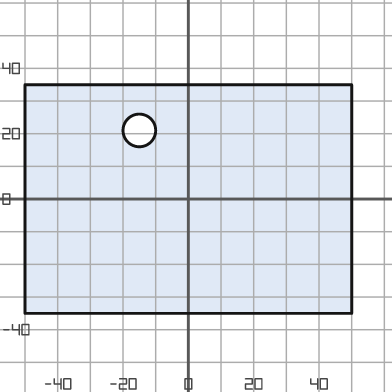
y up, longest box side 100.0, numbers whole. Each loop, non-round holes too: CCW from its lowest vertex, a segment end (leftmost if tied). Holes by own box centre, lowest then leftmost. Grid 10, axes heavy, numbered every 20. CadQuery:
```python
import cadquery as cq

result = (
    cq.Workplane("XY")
    .moveTo(-50.0, -35.0)
    .lineTo(50.0, -35.0)
    .lineTo(50.0, 35.0)
    .lineTo(-50.0, 35.0)
    .close()
    .moveTo(-15.0, 21.0)
    .circle(5.0)
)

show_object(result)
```